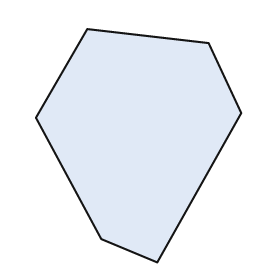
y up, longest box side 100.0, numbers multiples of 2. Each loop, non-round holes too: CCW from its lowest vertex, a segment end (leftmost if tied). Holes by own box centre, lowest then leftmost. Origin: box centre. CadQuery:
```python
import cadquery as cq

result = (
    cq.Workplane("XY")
    .moveTo(8.0, -50.0)
    .lineTo(44.0, 14.0)
    .lineTo(30.0, 44.0)
    .lineTo(-22.0, 50.0)
    .lineTo(-44.0, 12.0)
    .lineTo(-16.0, -40.0)
    .close()
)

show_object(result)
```